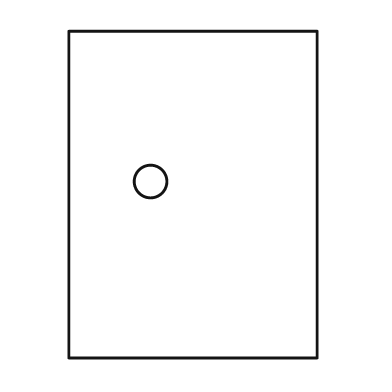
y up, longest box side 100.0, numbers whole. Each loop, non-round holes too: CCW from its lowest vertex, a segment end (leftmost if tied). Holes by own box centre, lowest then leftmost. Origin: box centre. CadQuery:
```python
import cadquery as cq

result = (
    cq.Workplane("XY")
    .moveTo(-38.0, -50.0)
    .lineTo(38.0, -50.0)
    .lineTo(38.0, 50.0)
    .lineTo(-38.0, 50.0)
    .close()
    .moveTo(-13.0, 4.0)
    .circle(5.0)
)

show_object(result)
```